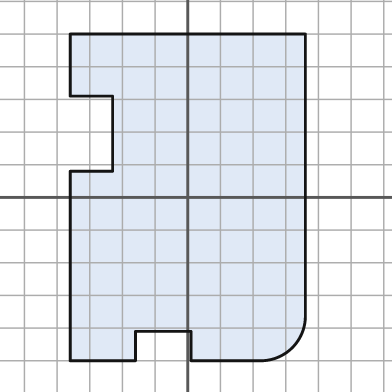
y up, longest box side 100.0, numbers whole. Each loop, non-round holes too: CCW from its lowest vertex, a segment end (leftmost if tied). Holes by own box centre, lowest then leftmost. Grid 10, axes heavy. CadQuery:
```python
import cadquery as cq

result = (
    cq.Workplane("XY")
    .moveTo(-36.0, -50.0)
    .lineTo(-16.0, -50.0)
    .lineTo(-16.0, -41.0)
    .lineTo(1.0, -41.0)
    .lineTo(1.0, -50.0)
    .lineTo(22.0, -50.0)
    .threePointArc((32.0, -46.0), (36.0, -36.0))
    .lineTo(36.0, 50.0)
    .lineTo(-36.0, 50.0)
    .lineTo(-36.0, 31.0)
    .lineTo(-23.0, 31.0)
    .lineTo(-23.0, 8.0)
    .lineTo(-36.0, 8.0)
    .close()
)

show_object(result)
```